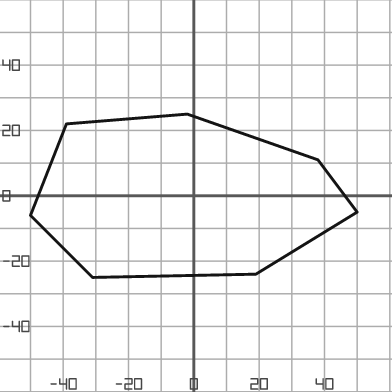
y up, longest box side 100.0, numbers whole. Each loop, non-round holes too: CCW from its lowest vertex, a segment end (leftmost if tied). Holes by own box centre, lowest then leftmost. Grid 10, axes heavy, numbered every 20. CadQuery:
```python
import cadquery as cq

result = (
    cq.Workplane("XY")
    .moveTo(-31.0, -25.0)
    .lineTo(19.0, -24.0)
    .lineTo(50.0, -5.0)
    .lineTo(38.0, 11.0)
    .lineTo(-2.0, 25.0)
    .lineTo(-39.0, 22.0)
    .lineTo(-50.0, -6.0)
    .close()
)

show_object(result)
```